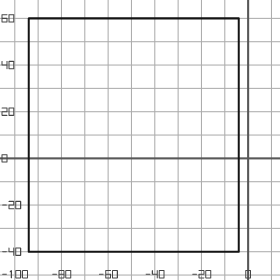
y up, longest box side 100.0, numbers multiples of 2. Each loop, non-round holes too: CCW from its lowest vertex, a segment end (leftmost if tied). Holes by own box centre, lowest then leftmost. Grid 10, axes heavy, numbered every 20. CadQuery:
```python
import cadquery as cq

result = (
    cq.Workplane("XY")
    .moveTo(-94.0, -40.0)
    .lineTo(-4.0, -40.0)
    .lineTo(-4.0, 60.0)
    .lineTo(-94.0, 60.0)
    .close()
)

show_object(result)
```